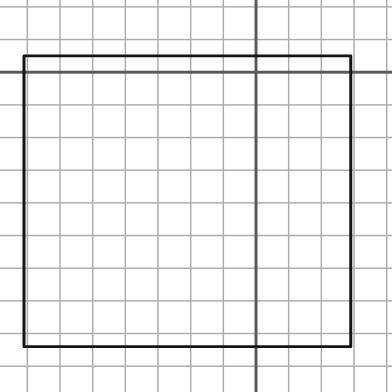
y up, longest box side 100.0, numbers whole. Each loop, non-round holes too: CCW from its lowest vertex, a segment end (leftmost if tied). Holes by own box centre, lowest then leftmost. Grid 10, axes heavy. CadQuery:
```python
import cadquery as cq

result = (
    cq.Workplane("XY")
    .moveTo(-71.0, -84.0)
    .lineTo(29.0, -84.0)
    .lineTo(29.0, 5.0)
    .lineTo(-71.0, 5.0)
    .close()
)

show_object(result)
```